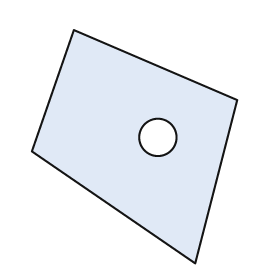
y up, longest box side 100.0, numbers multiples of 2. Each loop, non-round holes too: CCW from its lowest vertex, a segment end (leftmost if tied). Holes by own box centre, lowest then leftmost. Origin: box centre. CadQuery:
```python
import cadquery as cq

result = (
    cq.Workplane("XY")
    .moveTo(26.0, -50.0)
    .lineTo(44.0, 20.0)
    .lineTo(-26.0, 50.0)
    .lineTo(-44.0, -2.0)
    .close()
    .moveTo(10.0, 4.0)
    .circle(8.0)
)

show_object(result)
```